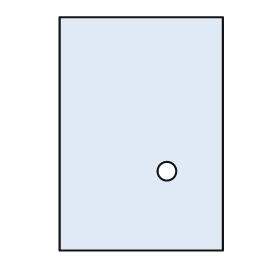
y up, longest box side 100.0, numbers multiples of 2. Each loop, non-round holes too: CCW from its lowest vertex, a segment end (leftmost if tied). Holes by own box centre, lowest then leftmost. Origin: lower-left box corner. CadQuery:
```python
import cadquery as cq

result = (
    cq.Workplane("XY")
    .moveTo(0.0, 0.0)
    .lineTo(70.0, 0.0)
    .lineTo(70.0, 100.0)
    .lineTo(0.0, 100.0)
    .close()
    .moveTo(46.0, 34.0)
    .circle(4.0)
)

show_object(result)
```